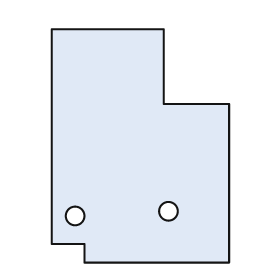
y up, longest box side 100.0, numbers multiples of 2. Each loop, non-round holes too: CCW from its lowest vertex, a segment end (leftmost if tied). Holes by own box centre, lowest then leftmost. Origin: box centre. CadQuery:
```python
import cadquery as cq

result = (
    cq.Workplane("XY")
    .moveTo(-24.0, -50.0)
    .lineTo(38.0, -50.0)
    .lineTo(38.0, 18.0)
    .lineTo(10.0, 18.0)
    .lineTo(10.0, 50.0)
    .lineTo(-38.0, 50.0)
    .lineTo(-38.0, -42.0)
    .lineTo(-24.0, -42.0)
    .close()
    .moveTo(-28.0, -30.0)
    .circle(4.0)
    .moveTo(12.0, -28.0)
    .circle(4.0)
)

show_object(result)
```